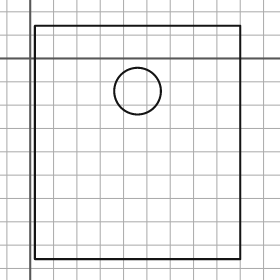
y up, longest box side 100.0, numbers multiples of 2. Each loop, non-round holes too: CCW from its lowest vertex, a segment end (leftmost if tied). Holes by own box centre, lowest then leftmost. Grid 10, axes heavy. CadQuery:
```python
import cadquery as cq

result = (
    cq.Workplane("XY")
    .moveTo(2.0, -86.0)
    .lineTo(90.0, -86.0)
    .lineTo(90.0, 14.0)
    .lineTo(2.0, 14.0)
    .close()
    .moveTo(46.0, -14.0)
    .circle(10.0)
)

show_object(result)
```